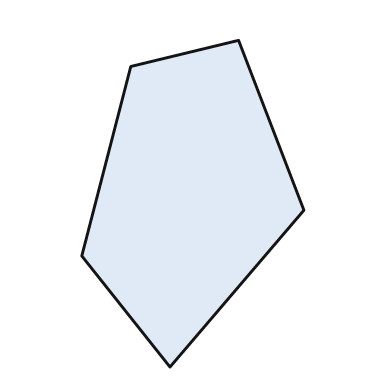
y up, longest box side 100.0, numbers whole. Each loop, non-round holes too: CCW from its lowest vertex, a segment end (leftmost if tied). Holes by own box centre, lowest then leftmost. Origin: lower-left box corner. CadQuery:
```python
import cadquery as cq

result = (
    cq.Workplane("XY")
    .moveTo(27.0, 0.0)
    .lineTo(68.0, 48.0)
    .lineTo(48.0, 100.0)
    .lineTo(15.0, 92.0)
    .lineTo(0.0, 34.0)
    .close()
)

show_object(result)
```